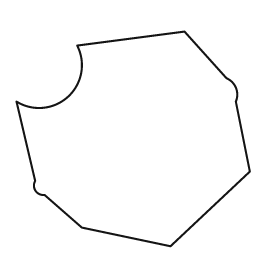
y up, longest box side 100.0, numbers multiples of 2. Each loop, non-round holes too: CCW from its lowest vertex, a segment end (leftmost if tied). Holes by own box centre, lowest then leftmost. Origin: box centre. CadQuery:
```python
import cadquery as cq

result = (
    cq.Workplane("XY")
    .moveTo(16.0, -46.0)
    .lineTo(50.0, -14.0)
    .lineTo(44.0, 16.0)
    .threePointArc((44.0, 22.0), (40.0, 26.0))
    .lineTo(22.0, 46.0)
    .lineTo(-24.0, 40.0)
    .threePointArc((-28.0, 18.0), (-50.0, 16.0))
    .lineTo(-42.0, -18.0)
    .threePointArc((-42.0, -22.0), (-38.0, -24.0))
    .lineTo(-22.0, -38.0)
    .close()
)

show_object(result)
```